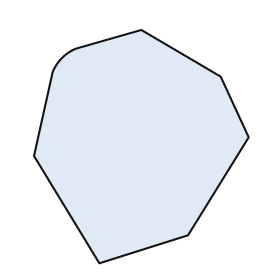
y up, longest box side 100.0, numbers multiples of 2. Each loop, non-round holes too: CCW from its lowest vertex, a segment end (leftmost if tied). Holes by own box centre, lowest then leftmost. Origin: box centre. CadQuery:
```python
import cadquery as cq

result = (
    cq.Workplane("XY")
    .moveTo(-18.0, -50.0)
    .lineTo(20.0, -38.0)
    .lineTo(46.0, 4.0)
    .lineTo(34.0, 30.0)
    .lineTo(0.0, 50.0)
    .lineTo(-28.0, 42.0)
    .threePointArc((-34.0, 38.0), (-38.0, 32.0))
    .lineTo(-46.0, -4.0)
    .close()
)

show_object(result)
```